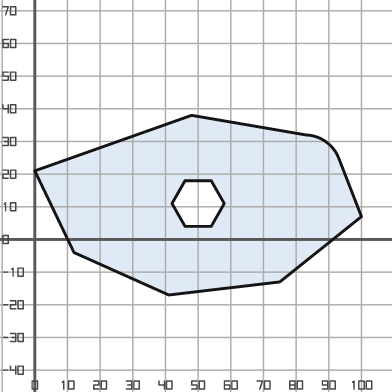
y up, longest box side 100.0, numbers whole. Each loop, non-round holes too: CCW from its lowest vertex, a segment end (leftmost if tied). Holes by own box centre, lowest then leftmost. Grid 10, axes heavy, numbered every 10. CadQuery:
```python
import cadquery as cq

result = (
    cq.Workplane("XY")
    .moveTo(41.0, -17.0)
    .lineTo(75.0, -13.0)
    .lineTo(100.0, 7.0)
    .lineTo(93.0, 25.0)
    .threePointArc((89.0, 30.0), (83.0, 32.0))
    .lineTo(48.0, 38.0)
    .lineTo(0.0, 21.0)
    .lineTo(12.0, -4.0)
    .close()
    .moveTo(46.0, 4.0)
    .lineTo(54.0, 4.0)
    .lineTo(58.0, 11.0)
    .lineTo(54.0, 18.0)
    .lineTo(46.0, 18.0)
    .lineTo(42.0, 11.0)
    .close()
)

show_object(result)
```